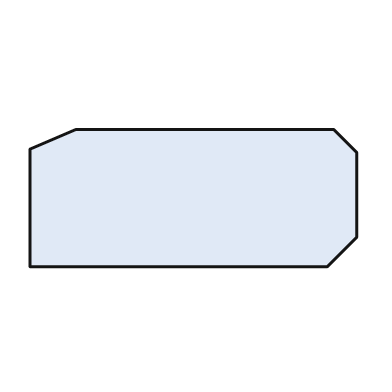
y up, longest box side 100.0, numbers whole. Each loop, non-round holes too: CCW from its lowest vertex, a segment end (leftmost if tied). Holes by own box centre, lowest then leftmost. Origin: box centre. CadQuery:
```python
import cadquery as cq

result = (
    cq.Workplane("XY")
    .moveTo(-50.0, -21.0)
    .lineTo(41.0, -21.0)
    .lineTo(50.0, -12.0)
    .lineTo(50.0, 14.0)
    .lineTo(43.0, 21.0)
    .lineTo(-36.0, 21.0)
    .lineTo(-50.0, 15.0)
    .close()
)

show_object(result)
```